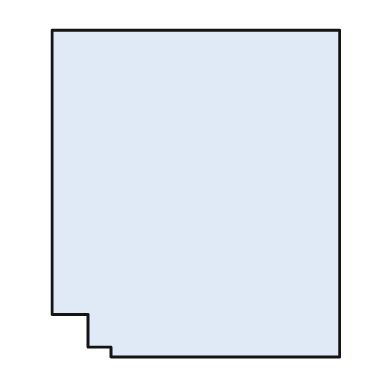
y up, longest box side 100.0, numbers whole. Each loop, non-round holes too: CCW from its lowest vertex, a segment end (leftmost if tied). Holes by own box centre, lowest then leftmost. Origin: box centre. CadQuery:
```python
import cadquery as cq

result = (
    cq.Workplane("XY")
    .moveTo(-26.0, -50.0)
    .lineTo(44.0, -50.0)
    .lineTo(44.0, 50.0)
    .lineTo(-44.0, 50.0)
    .lineTo(-44.0, -37.0)
    .lineTo(-33.0, -37.0)
    .lineTo(-33.0, -47.0)
    .lineTo(-26.0, -47.0)
    .close()
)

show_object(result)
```